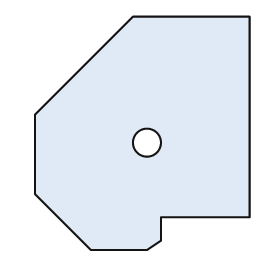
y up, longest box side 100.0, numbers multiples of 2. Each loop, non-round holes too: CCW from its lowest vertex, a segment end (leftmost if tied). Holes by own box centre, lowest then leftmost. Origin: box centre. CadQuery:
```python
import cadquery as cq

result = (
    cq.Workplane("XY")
    .moveTo(-22.0, -50.0)
    .lineTo(2.0, -50.0)
    .lineTo(8.0, -46.0)
    .lineTo(8.0, -36.0)
    .lineTo(46.0, -36.0)
    .lineTo(46.0, 50.0)
    .lineTo(-4.0, 50.0)
    .lineTo(-46.0, 8.0)
    .lineTo(-46.0, -26.0)
    .close()
    .moveTo(2.0, -4.0)
    .circle(6.0)
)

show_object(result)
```